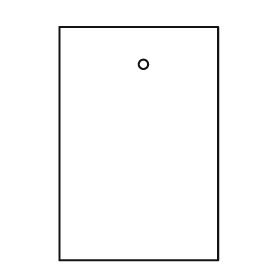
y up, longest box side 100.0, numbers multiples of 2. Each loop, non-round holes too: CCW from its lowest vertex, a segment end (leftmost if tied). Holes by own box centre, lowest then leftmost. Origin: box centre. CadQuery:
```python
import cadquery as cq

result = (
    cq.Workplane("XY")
    .moveTo(-34.0, -50.0)
    .lineTo(34.0, -50.0)
    .lineTo(34.0, 50.0)
    .lineTo(-34.0, 50.0)
    .close()
    .moveTo(2.0, 34.0)
    .circle(2.0)
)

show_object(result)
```